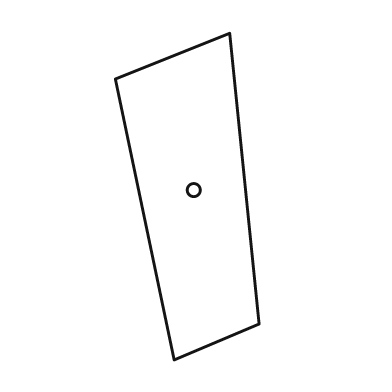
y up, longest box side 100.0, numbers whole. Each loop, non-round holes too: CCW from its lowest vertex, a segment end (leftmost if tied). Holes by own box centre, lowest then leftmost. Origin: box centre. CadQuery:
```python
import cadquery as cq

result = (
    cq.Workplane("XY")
    .moveTo(-4.0, -50.0)
    .lineTo(22.0, -39.0)
    .lineTo(13.0, 50.0)
    .lineTo(-22.0, 36.0)
    .close()
    .moveTo(2.0, 2.0)
    .circle(2.0)
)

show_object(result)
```